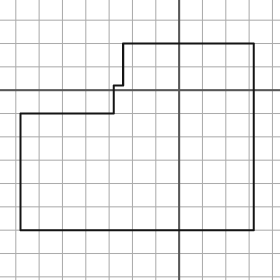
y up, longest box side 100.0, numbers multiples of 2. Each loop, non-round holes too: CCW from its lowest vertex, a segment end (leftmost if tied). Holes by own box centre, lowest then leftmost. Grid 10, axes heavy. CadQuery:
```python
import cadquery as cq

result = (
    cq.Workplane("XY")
    .moveTo(-68.0, -60.0)
    .lineTo(32.0, -60.0)
    .lineTo(32.0, 20.0)
    .lineTo(-24.0, 20.0)
    .lineTo(-24.0, 2.0)
    .lineTo(-28.0, 2.0)
    .lineTo(-28.0, -10.0)
    .lineTo(-68.0, -10.0)
    .close()
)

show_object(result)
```